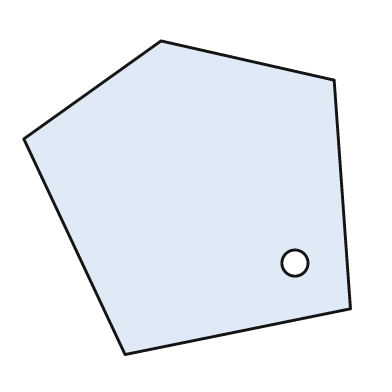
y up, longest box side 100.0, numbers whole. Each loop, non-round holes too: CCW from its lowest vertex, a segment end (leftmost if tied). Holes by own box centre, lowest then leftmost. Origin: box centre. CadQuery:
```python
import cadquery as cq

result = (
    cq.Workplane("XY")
    .moveTo(-19.0, -48.0)
    .lineTo(50.0, -34.0)
    .lineTo(45.0, 36.0)
    .lineTo(-8.0, 48.0)
    .lineTo(-50.0, 18.0)
    .close()
    .moveTo(33.0, -20.0)
    .circle(4.0)
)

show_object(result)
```